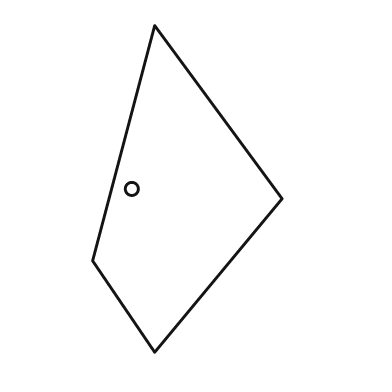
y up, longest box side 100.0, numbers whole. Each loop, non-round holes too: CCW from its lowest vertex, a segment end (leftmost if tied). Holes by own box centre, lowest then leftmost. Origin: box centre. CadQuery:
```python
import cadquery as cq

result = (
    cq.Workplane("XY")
    .moveTo(-10.0, -50.0)
    .lineTo(29.0, -3.0)
    .lineTo(-10.0, 50.0)
    .lineTo(-29.0, -22.0)
    .close()
    .moveTo(-17.0, 0.0)
    .circle(2.0)
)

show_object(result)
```